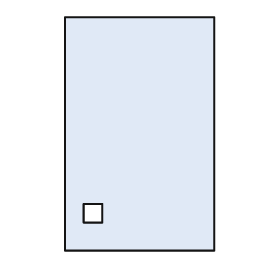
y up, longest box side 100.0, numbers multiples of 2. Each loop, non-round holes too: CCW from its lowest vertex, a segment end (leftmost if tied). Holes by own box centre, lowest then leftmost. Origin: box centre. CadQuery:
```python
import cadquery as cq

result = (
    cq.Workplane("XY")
    .moveTo(-32.0, -50.0)
    .lineTo(32.0, -50.0)
    .lineTo(32.0, 50.0)
    .lineTo(-32.0, 50.0)
    .close()
    .moveTo(-24.0, -38.0)
    .lineTo(-16.0, -38.0)
    .lineTo(-16.0, -30.0)
    .lineTo(-24.0, -30.0)
    .close()
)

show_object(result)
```